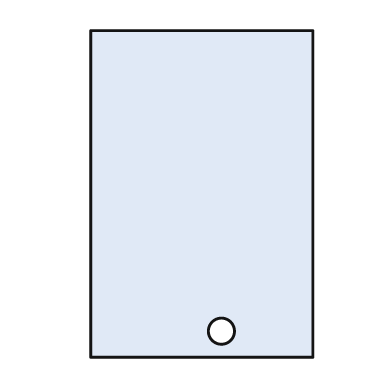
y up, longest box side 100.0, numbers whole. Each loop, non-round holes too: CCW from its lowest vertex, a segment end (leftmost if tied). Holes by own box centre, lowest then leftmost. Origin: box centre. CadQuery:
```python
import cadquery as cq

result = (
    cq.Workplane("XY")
    .moveTo(-34.0, -50.0)
    .lineTo(34.0, -50.0)
    .lineTo(34.0, 50.0)
    .lineTo(-34.0, 50.0)
    .close()
    .moveTo(6.0, -42.0)
    .circle(4.0)
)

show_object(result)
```